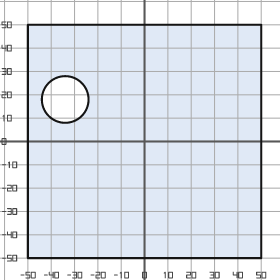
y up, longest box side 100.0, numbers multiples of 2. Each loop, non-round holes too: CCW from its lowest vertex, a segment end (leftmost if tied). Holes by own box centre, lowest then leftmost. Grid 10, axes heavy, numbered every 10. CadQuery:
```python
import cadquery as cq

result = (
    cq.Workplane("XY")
    .moveTo(-50.0, -50.0)
    .lineTo(50.0, -50.0)
    .lineTo(50.0, 50.0)
    .lineTo(-50.0, 50.0)
    .close()
    .moveTo(-34.0, 18.0)
    .circle(10.0)
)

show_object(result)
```